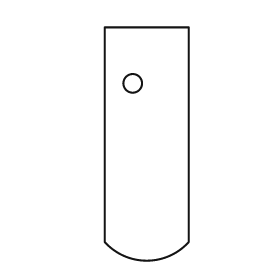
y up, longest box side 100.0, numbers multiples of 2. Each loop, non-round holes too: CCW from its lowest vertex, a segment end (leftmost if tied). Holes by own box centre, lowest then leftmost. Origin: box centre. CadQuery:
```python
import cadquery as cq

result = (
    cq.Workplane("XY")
    .moveTo(-18.0, -42.0)
    .threePointArc((0.0, -50.0), (18.0, -42.0))
    .lineTo(18.0, 50.0)
    .lineTo(-18.0, 50.0)
    .close()
    .moveTo(-6.0, 26.0)
    .circle(4.0)
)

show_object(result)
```